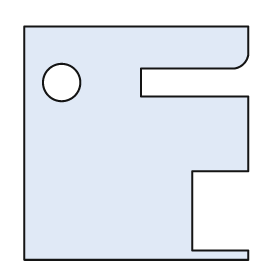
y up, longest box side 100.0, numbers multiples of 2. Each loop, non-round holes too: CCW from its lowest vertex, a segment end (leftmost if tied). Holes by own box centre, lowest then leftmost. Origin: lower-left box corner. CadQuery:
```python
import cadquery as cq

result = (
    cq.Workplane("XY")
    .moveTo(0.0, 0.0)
    .lineTo(96.0, 0.0)
    .lineTo(96.0, 4.0)
    .lineTo(72.0, 4.0)
    .lineTo(72.0, 38.0)
    .lineTo(96.0, 38.0)
    .lineTo(96.0, 70.0)
    .lineTo(50.0, 70.0)
    .lineTo(50.0, 82.0)
    .lineTo(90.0, 82.0)
    .threePointArc((94.0, 84.0), (96.0, 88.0))
    .lineTo(96.0, 100.0)
    .lineTo(0.0, 100.0)
    .close()
    .moveTo(16.0, 76.0)
    .circle(8.0)
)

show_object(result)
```